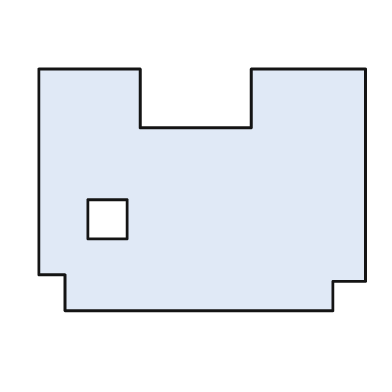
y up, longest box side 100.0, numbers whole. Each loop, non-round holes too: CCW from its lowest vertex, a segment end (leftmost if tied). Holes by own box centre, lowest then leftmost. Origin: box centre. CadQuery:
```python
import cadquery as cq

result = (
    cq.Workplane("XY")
    .moveTo(-42.0, -37.0)
    .lineTo(40.0, -37.0)
    .lineTo(40.0, -28.0)
    .lineTo(50.0, -28.0)
    .lineTo(50.0, 37.0)
    .lineTo(15.0, 37.0)
    .lineTo(15.0, 19.0)
    .lineTo(-19.0, 19.0)
    .lineTo(-19.0, 37.0)
    .lineTo(-50.0, 37.0)
    .lineTo(-50.0, -26.0)
    .lineTo(-42.0, -26.0)
    .close()
    .moveTo(-35.0, -15.0)
    .lineTo(-23.0, -15.0)
    .lineTo(-23.0, -3.0)
    .lineTo(-35.0, -3.0)
    .close()
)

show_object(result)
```